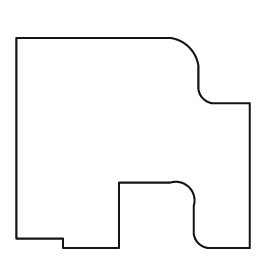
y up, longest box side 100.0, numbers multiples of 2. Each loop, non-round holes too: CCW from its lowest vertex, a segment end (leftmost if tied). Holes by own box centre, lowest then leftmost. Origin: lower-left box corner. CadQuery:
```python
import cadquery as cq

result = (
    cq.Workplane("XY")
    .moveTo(20.0, 0.0)
    .lineTo(44.0, 0.0)
    .lineTo(44.0, 28.0)
    .lineTo(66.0, 28.0)
    .threePointArc((74.0, 26.0), (76.0, 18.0))
    .lineTo(76.0, 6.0)
    .threePointArc((78.0, 2.0), (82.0, 0.0))
    .lineTo(100.0, 0.0)
    .lineTo(100.0, 62.0)
    .lineTo(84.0, 62.0)
    .threePointArc((80.0, 64.0), (78.0, 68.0))
    .lineTo(78.0, 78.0)
    .threePointArc((74.0, 86.0), (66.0, 90.0))
    .lineTo(0.0, 90.0)
    .lineTo(0.0, 4.0)
    .lineTo(20.0, 4.0)
    .close()
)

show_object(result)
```